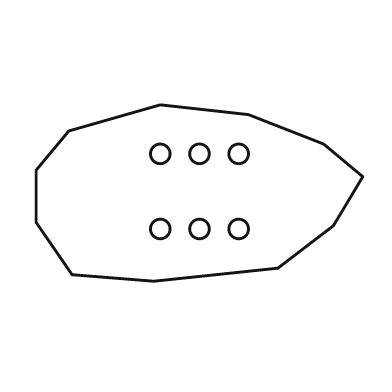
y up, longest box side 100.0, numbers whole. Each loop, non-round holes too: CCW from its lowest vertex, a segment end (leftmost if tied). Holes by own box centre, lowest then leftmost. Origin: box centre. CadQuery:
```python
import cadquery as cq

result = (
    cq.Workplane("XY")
    .moveTo(-14.0, -27.0)
    .lineTo(24.0, -23.0)
    .lineTo(41.0, -10.0)
    .lineTo(50.0, 5.0)
    .lineTo(38.0, 15.0)
    .lineTo(15.0, 24.0)
    .lineTo(-12.0, 27.0)
    .lineTo(-40.0, 19.0)
    .lineTo(-50.0, 7.0)
    .lineTo(-50.0, -9.0)
    .lineTo(-39.0, -25.0)
    .close()
    .moveTo(-12.0, -11.0)
    .circle(3.0)
    .moveTo(0.0, -11.0)
    .circle(3.0)
    .moveTo(12.0, -11.0)
    .circle(3.0)
    .moveTo(-12.0, 12.0)
    .circle(3.0)
    .moveTo(0.0, 12.0)
    .circle(3.0)
    .moveTo(12.0, 12.0)
    .circle(3.0)
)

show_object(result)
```